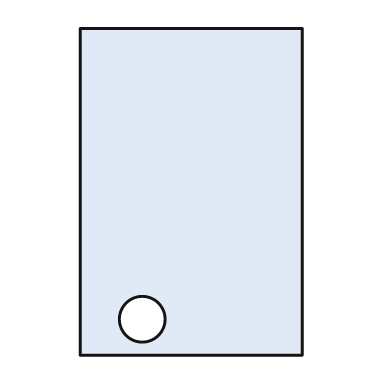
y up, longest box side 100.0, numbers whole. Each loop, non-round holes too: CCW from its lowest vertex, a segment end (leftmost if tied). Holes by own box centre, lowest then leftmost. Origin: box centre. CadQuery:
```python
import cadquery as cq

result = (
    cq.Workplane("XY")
    .moveTo(-34.0, -50.0)
    .lineTo(34.0, -50.0)
    .lineTo(34.0, 50.0)
    .lineTo(-34.0, 50.0)
    .close()
    .moveTo(-15.0, -39.0)
    .circle(7.0)
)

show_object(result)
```